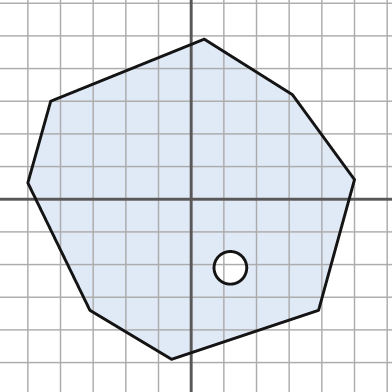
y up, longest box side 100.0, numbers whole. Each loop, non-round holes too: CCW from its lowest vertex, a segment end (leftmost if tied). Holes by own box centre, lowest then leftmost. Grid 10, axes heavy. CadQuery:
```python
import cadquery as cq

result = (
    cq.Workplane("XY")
    .moveTo(-6.0, -49.0)
    .lineTo(39.0, -34.0)
    .lineTo(50.0, 6.0)
    .lineTo(31.0, 32.0)
    .lineTo(4.0, 49.0)
    .lineTo(-43.0, 30.0)
    .lineTo(-50.0, 5.0)
    .lineTo(-31.0, -34.0)
    .close()
    .moveTo(12.0, -21.0)
    .circle(5.0)
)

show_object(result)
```